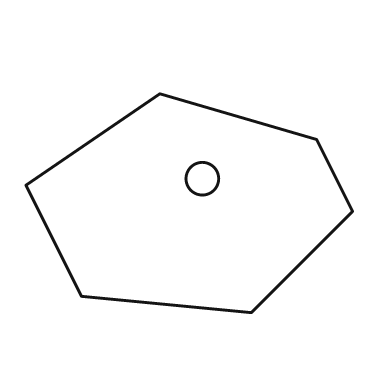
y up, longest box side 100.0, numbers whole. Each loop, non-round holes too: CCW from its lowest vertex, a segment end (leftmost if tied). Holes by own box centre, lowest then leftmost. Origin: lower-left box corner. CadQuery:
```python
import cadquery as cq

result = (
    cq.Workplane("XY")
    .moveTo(69.0, 0.0)
    .lineTo(100.0, 31.0)
    .lineTo(89.0, 53.0)
    .lineTo(41.0, 67.0)
    .lineTo(0.0, 39.0)
    .lineTo(17.0, 5.0)
    .close()
    .moveTo(54.0, 41.0)
    .circle(5.0)
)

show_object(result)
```